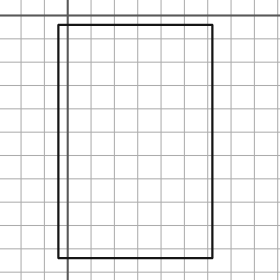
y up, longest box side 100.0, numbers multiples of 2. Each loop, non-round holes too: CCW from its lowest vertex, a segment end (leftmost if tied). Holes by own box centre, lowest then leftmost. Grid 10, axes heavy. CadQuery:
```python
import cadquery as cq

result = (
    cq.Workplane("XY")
    .moveTo(-4.0, -104.0)
    .lineTo(62.0, -104.0)
    .lineTo(62.0, -4.0)
    .lineTo(-4.0, -4.0)
    .close()
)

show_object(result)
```